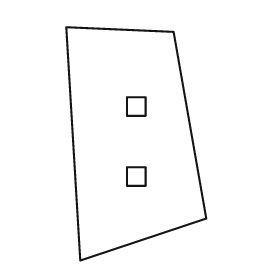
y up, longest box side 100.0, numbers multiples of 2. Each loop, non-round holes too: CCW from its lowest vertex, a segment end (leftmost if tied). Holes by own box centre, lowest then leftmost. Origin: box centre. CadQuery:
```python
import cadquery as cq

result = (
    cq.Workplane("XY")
    .moveTo(-24.0, -50.0)
    .lineTo(30.0, -32.0)
    .lineTo(16.0, 48.0)
    .lineTo(-30.0, 50.0)
    .close()
    .moveTo(-4.0, -18.0)
    .lineTo(4.0, -18.0)
    .lineTo(4.0, -10.0)
    .lineTo(-4.0, -10.0)
    .close()
    .moveTo(-4.0, 12.0)
    .lineTo(4.0, 12.0)
    .lineTo(4.0, 20.0)
    .lineTo(-4.0, 20.0)
    .close()
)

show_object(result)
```